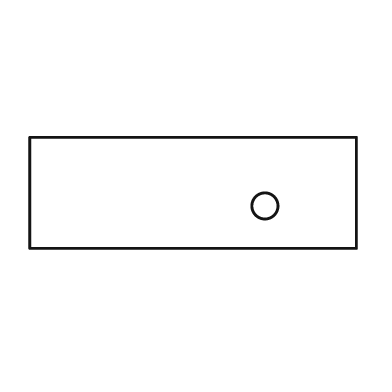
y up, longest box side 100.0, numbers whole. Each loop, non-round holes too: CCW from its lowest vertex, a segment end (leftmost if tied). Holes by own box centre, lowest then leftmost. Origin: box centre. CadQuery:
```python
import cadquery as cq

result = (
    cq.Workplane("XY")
    .moveTo(-50.0, -17.0)
    .lineTo(50.0, -17.0)
    .lineTo(50.0, 17.0)
    .lineTo(-50.0, 17.0)
    .close()
    .moveTo(22.0, -4.0)
    .circle(4.0)
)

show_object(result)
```